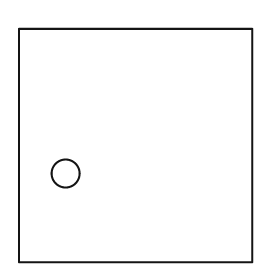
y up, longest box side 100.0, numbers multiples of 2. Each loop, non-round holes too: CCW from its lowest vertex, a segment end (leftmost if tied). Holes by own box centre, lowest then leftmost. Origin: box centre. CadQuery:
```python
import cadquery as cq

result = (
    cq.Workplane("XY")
    .moveTo(-50.0, -50.0)
    .lineTo(50.0, -50.0)
    .lineTo(50.0, 50.0)
    .lineTo(-50.0, 50.0)
    .close()
    .moveTo(-30.0, -12.0)
    .circle(6.0)
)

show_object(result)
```